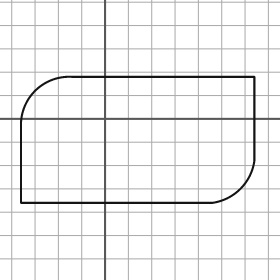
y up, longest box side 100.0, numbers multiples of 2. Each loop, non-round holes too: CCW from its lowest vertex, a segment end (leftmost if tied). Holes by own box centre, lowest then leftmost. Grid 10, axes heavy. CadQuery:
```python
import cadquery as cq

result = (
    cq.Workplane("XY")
    .moveTo(-36.0, -36.0)
    .lineTo(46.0, -36.0)
    .threePointArc((58.0, -30.0), (64.0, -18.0))
    .lineTo(64.0, 18.0)
    .lineTo(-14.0, 18.0)
    .threePointArc((-30.0, 12.0), (-36.0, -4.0))
    .close()
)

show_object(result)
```